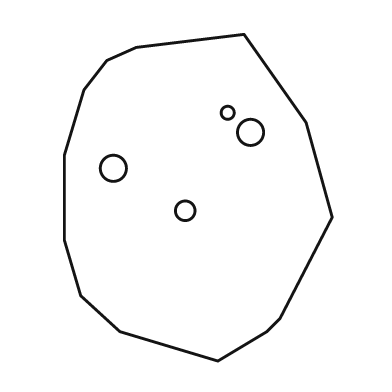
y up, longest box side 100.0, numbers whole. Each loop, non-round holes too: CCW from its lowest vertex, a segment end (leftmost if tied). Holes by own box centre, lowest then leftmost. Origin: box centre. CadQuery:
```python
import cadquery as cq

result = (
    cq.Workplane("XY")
    .moveTo(6.0, -50.0)
    .lineTo(21.0, -41.0)
    .lineTo(25.0, -37.0)
    .lineTo(41.0, -6.0)
    .lineTo(33.0, 23.0)
    .lineTo(14.0, 50.0)
    .lineTo(-19.0, 46.0)
    .lineTo(-28.0, 42.0)
    .lineTo(-35.0, 33.0)
    .lineTo(-41.0, 13.0)
    .lineTo(-41.0, -13.0)
    .lineTo(-36.0, -30.0)
    .lineTo(-24.0, -41.0)
    .close()
    .moveTo(-4.0, -4.0)
    .circle(3.0)
    .moveTo(-26.0, 9.0)
    .circle(4.0)
    .moveTo(16.0, 20.0)
    .circle(4.0)
    .moveTo(9.0, 26.0)
    .circle(2.0)
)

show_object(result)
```